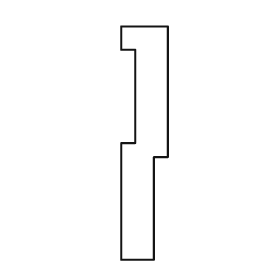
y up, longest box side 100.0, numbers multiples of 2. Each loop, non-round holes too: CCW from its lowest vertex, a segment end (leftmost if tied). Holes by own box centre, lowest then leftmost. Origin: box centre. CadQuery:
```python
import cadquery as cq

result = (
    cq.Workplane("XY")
    .moveTo(-10.0, -50.0)
    .lineTo(4.0, -50.0)
    .lineTo(4.0, -6.0)
    .lineTo(10.0, -6.0)
    .lineTo(10.0, 50.0)
    .lineTo(-10.0, 50.0)
    .lineTo(-10.0, 40.0)
    .lineTo(-4.0, 40.0)
    .lineTo(-4.0, 0.0)
    .lineTo(-10.0, 0.0)
    .close()
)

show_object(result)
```